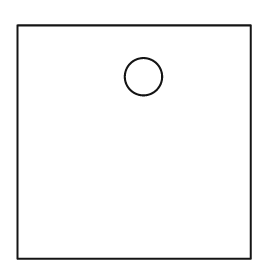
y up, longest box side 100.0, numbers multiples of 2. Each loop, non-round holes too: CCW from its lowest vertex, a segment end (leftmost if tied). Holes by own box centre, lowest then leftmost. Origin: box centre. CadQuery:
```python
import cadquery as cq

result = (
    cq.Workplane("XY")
    .moveTo(-50.0, -50.0)
    .lineTo(50.0, -50.0)
    .lineTo(50.0, 50.0)
    .lineTo(-50.0, 50.0)
    .close()
    .moveTo(4.0, 28.0)
    .circle(8.0)
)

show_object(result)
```